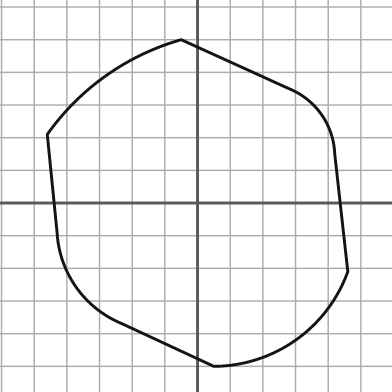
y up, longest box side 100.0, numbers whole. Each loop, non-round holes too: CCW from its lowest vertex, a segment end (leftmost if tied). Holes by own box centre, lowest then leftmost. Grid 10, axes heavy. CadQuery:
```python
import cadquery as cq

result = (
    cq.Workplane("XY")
    .moveTo(5.0, -50.0)
    .threePointArc((30.0, -42.0), (46.0, -21.0))
    .lineTo(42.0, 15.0)
    .threePointArc((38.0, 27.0), (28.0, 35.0))
    .lineTo(-5.0, 50.0)
    .threePointArc((-28.0, 39.0), (-46.0, 21.0))
    .lineTo(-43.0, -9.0)
    .threePointArc((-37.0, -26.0), (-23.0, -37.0))
    .close()
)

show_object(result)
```